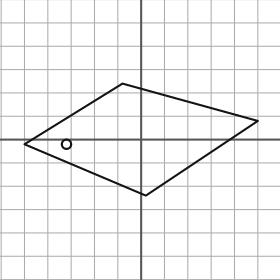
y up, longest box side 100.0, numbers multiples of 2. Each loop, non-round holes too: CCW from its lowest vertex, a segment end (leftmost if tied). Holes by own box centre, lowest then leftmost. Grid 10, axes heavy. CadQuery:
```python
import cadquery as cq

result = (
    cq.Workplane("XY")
    .moveTo(2.0, -24.0)
    .lineTo(50.0, 8.0)
    .lineTo(-8.0, 24.0)
    .lineTo(-50.0, -2.0)
    .close()
    .moveTo(-32.0, -2.0)
    .circle(2.0)
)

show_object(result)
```